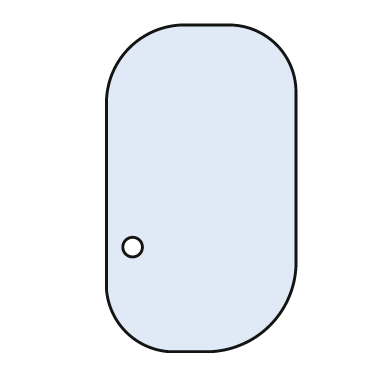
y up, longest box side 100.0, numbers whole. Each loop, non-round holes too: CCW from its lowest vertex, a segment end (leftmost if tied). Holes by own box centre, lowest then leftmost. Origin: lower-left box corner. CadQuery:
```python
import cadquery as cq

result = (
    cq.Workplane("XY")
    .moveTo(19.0, 0.0)
    .lineTo(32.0, 0.0)
    .threePointArc((50.0, 8.0), (58.0, 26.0))
    .lineTo(58.0, 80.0)
    .threePointArc((52.0, 94.0), (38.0, 100.0))
    .lineTo(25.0, 100.0)
    .threePointArc((7.0, 93.0), (0.0, 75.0))
    .lineTo(0.0, 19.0)
    .threePointArc((6.0, 6.0), (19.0, 0.0))
    .close()
    .moveTo(8.0, 32.0)
    .circle(3.0)
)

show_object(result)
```